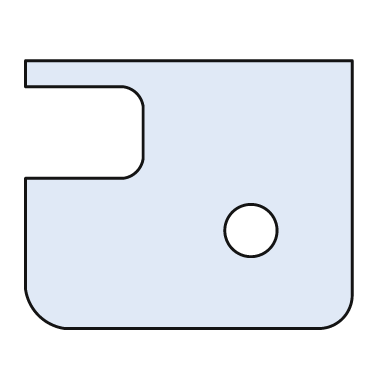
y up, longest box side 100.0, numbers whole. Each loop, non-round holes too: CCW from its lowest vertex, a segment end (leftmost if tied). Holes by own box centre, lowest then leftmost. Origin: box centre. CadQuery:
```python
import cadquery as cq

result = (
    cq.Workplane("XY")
    .moveTo(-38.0, -41.0)
    .lineTo(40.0, -41.0)
    .threePointArc((47.0, -38.0), (50.0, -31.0))
    .lineTo(50.0, 41.0)
    .lineTo(-50.0, 41.0)
    .lineTo(-50.0, 33.0)
    .lineTo(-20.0, 33.0)
    .threePointArc((-16.0, 31.0), (-14.0, 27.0))
    .lineTo(-14.0, 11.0)
    .threePointArc((-16.0, 7.0), (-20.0, 5.0))
    .lineTo(-50.0, 5.0)
    .lineTo(-50.0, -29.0)
    .threePointArc((-46.0, -37.0), (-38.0, -41.0))
    .close()
    .moveTo(19.0, -11.0)
    .circle(8.0)
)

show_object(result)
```